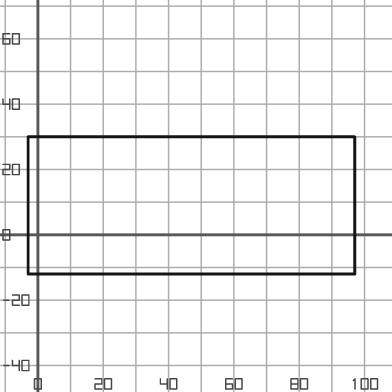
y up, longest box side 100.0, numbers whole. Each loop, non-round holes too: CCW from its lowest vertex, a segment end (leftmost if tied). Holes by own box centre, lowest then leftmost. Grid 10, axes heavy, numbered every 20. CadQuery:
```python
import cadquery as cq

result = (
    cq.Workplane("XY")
    .moveTo(-3.0, -12.0)
    .lineTo(97.0, -12.0)
    .lineTo(97.0, 30.0)
    .lineTo(-3.0, 30.0)
    .close()
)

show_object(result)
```